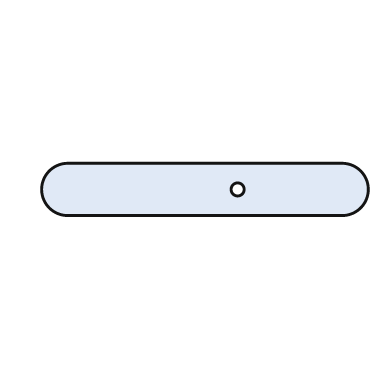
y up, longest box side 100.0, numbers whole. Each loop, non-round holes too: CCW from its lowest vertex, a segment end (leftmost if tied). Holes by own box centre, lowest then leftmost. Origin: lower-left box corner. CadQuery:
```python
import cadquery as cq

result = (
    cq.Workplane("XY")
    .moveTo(8.0, 0.0)
    .lineTo(92.0, 0.0)
    .threePointArc((100.0, 8.0), (92.0, 16.0))
    .lineTo(8.0, 16.0)
    .threePointArc((0.0, 8.0), (8.0, 0.0))
    .close()
    .moveTo(60.0, 8.0)
    .circle(2.0)
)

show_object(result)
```